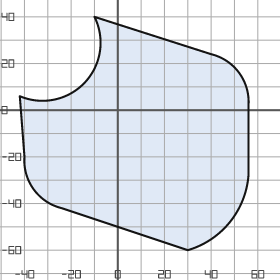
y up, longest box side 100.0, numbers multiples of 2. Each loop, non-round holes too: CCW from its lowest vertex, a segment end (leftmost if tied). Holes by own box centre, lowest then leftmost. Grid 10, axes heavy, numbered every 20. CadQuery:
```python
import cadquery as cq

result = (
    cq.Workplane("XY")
    .moveTo(30.0, -60.0)
    .threePointArc((48.0, -48.0), (56.0, -28.0))
    .lineTo(56.0, 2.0)
    .threePointArc((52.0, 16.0), (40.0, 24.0))
    .lineTo(-10.0, 40.0)
    .threePointArc((-14.0, 12.0), (-42.0, 6.0))
    .lineTo(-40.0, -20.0)
    .threePointArc((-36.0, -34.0), (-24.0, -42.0))
    .close()
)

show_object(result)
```